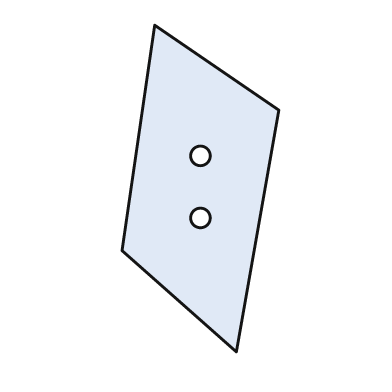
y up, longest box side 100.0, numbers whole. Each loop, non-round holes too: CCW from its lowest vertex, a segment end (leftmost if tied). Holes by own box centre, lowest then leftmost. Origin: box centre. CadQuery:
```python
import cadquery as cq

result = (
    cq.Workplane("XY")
    .moveTo(11.0, -50.0)
    .lineTo(24.0, 24.0)
    .lineTo(-14.0, 50.0)
    .lineTo(-24.0, -19.0)
    .close()
    .moveTo(0.0, -9.0)
    .circle(3.0)
    .moveTo(0.0, 10.0)
    .circle(3.0)
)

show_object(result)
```